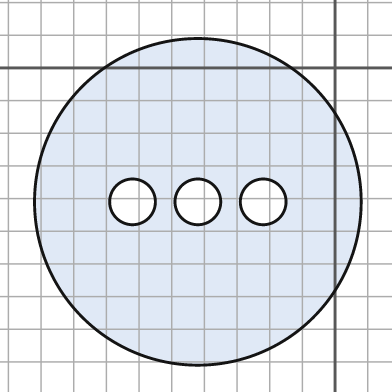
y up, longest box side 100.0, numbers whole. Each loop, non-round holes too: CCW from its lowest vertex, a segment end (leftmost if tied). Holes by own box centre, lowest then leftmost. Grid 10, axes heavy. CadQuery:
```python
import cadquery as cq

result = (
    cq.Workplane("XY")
    .moveTo(-42.0, -41.0)
    .circle(50.0)
    .moveTo(-62.0, -41.0)
    .circle(7.0)
    .moveTo(-42.0, -41.0)
    .circle(7.0)
    .moveTo(-22.0, -41.0)
    .circle(7.0)
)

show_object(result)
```